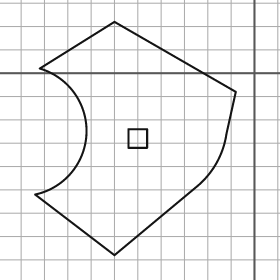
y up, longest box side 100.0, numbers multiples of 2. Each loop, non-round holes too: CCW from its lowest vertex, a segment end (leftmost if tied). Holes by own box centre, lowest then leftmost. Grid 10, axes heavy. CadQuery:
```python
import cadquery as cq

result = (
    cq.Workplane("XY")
    .moveTo(-60.0, -78.0)
    .lineTo(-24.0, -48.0)
    .threePointArc((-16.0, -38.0), (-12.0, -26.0))
    .lineTo(-8.0, -8.0)
    .lineTo(-60.0, 22.0)
    .lineTo(-92.0, 2.0)
    .threePointArc((-72.0, -26.0), (-94.0, -52.0))
    .close()
    .moveTo(-54.0, -32.0)
    .lineTo(-46.0, -32.0)
    .lineTo(-46.0, -24.0)
    .lineTo(-54.0, -24.0)
    .close()
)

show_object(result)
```